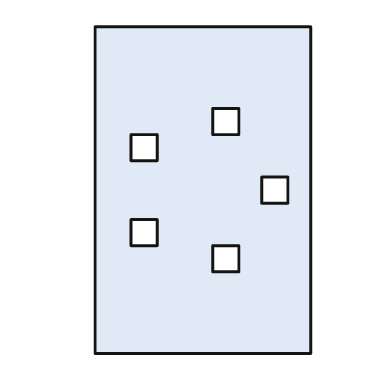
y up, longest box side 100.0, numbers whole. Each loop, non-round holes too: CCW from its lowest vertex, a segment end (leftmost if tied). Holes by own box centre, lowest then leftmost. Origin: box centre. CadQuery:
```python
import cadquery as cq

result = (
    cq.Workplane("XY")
    .moveTo(-33.0, -50.0)
    .lineTo(33.0, -50.0)
    .lineTo(33.0, 50.0)
    .lineTo(-33.0, 50.0)
    .close()
    .moveTo(3.0, -25.0)
    .lineTo(11.0, -25.0)
    .lineTo(11.0, -17.0)
    .lineTo(3.0, -17.0)
    .close()
    .moveTo(-22.0, -17.0)
    .lineTo(-14.0, -17.0)
    .lineTo(-14.0, -9.0)
    .lineTo(-22.0, -9.0)
    .close()
    .moveTo(18.0, -4.0)
    .lineTo(26.0, -4.0)
    .lineTo(26.0, 4.0)
    .lineTo(18.0, 4.0)
    .close()
    .moveTo(-22.0, 9.0)
    .lineTo(-14.0, 9.0)
    .lineTo(-14.0, 17.0)
    .lineTo(-22.0, 17.0)
    .close()
    .moveTo(3.0, 17.0)
    .lineTo(11.0, 17.0)
    .lineTo(11.0, 25.0)
    .lineTo(3.0, 25.0)
    .close()
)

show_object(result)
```